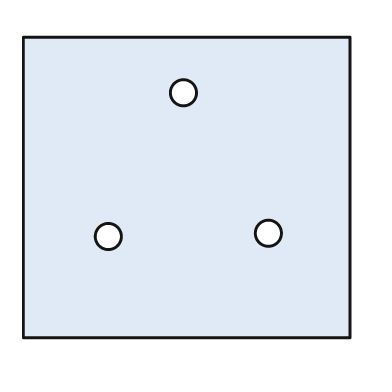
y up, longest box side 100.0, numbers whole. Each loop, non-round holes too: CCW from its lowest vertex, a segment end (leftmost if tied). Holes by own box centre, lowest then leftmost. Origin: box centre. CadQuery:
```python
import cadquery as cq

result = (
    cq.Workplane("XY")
    .moveTo(-50.0, -46.0)
    .lineTo(50.0, -46.0)
    .lineTo(50.0, 46.0)
    .lineTo(-50.0, 46.0)
    .close()
    .moveTo(-24.0, -15.0)
    .circle(4.0)
    .moveTo(25.0, -14.0)
    .circle(4.0)
    .moveTo(-1.0, 29.0)
    .circle(4.0)
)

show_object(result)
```